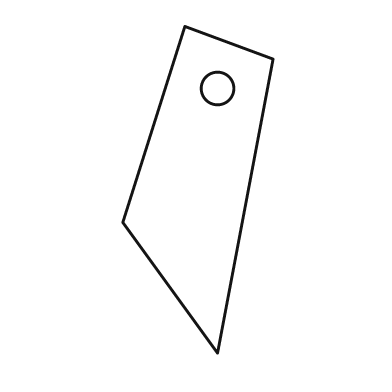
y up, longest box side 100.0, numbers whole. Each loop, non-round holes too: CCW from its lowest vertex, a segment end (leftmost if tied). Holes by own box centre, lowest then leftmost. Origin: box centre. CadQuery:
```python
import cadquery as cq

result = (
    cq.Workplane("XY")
    .moveTo(6.0, -50.0)
    .lineTo(23.0, 40.0)
    .lineTo(-4.0, 50.0)
    .lineTo(-23.0, -10.0)
    .close()
    .moveTo(6.0, 31.0)
    .circle(5.0)
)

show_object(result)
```